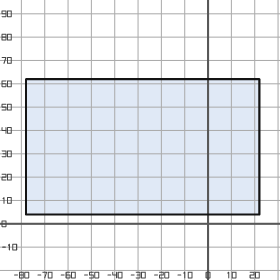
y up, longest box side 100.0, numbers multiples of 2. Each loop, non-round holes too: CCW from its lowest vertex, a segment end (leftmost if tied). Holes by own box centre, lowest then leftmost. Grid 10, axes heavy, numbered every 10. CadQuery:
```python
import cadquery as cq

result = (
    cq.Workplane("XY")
    .moveTo(-78.0, 4.0)
    .lineTo(22.0, 4.0)
    .lineTo(22.0, 62.0)
    .lineTo(-78.0, 62.0)
    .close()
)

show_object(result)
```